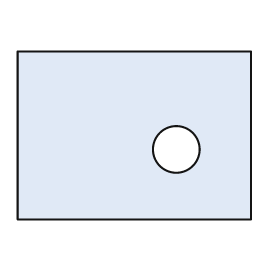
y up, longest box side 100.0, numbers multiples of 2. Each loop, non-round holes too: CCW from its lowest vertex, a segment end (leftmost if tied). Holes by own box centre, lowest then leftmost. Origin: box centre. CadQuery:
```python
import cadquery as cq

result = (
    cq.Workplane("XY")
    .moveTo(-50.0, -36.0)
    .lineTo(50.0, -36.0)
    .lineTo(50.0, 36.0)
    .lineTo(-50.0, 36.0)
    .close()
    .moveTo(18.0, -6.0)
    .circle(10.0)
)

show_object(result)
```